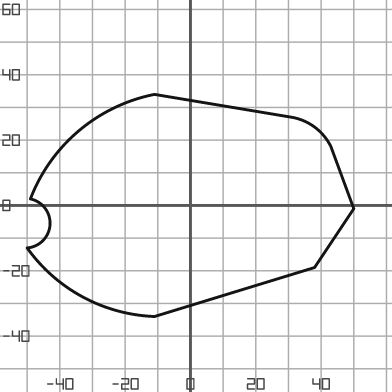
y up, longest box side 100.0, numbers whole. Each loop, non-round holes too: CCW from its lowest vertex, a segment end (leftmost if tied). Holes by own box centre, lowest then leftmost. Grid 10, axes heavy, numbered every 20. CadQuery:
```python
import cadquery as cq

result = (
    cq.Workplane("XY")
    .moveTo(-11.0, -34.0)
    .lineTo(38.0, -19.0)
    .lineTo(50.0, -1.0)
    .lineTo(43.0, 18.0)
    .threePointArc((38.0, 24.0), (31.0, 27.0))
    .lineTo(-11.0, 34.0)
    .threePointArc((-34.0, 23.0), (-49.0, 2.0))
    .threePointArc((-43.0, -6.0), (-50.0, -13.0))
    .threePointArc((-33.0, -28.0), (-11.0, -34.0))
    .close()
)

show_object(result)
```